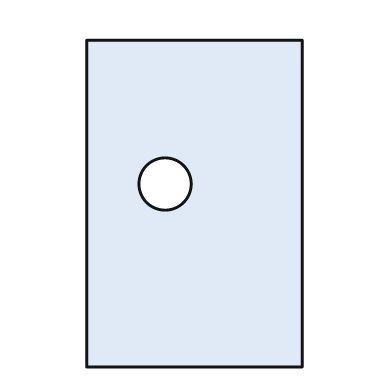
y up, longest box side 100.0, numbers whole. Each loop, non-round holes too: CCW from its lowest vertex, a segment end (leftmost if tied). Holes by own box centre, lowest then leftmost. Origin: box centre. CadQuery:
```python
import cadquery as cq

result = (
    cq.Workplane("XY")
    .moveTo(-33.0, -50.0)
    .lineTo(33.0, -50.0)
    .lineTo(33.0, 50.0)
    .lineTo(-33.0, 50.0)
    .close()
    .moveTo(-9.0, 6.0)
    .circle(8.0)
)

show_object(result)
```